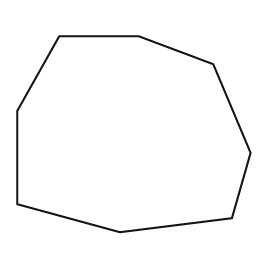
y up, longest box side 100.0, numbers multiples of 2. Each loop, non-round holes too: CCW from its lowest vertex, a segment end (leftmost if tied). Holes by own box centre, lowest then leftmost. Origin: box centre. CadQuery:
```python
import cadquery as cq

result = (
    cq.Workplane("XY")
    .moveTo(-6.0, -42.0)
    .lineTo(42.0, -36.0)
    .lineTo(50.0, -8.0)
    .lineTo(34.0, 30.0)
    .lineTo(2.0, 42.0)
    .lineTo(-32.0, 42.0)
    .lineTo(-50.0, 10.0)
    .lineTo(-50.0, -30.0)
    .close()
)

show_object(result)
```